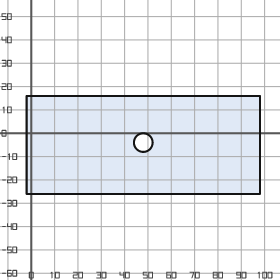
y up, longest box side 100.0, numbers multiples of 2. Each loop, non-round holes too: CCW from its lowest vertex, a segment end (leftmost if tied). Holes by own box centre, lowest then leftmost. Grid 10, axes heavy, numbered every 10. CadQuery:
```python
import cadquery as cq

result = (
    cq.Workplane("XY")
    .moveTo(-2.0, -26.0)
    .lineTo(98.0, -26.0)
    .lineTo(98.0, 16.0)
    .lineTo(-2.0, 16.0)
    .close()
    .moveTo(48.0, -4.0)
    .circle(4.0)
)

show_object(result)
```